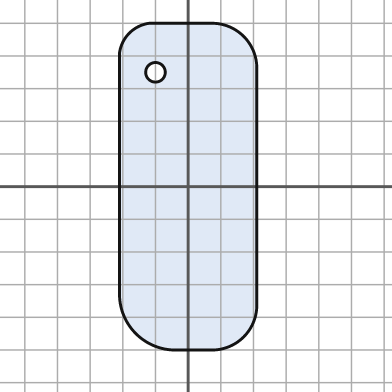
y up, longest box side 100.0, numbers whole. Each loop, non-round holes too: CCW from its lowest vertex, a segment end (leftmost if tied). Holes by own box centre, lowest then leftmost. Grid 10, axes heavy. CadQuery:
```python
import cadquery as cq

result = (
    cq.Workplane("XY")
    .moveTo(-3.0, -50.0)
    .lineTo(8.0, -50.0)
    .threePointArc((17.0, -46.0), (21.0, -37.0))
    .lineTo(21.0, 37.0)
    .threePointArc((17.0, 46.0), (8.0, 50.0))
    .lineTo(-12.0, 50.0)
    .threePointArc((-18.0, 47.0), (-21.0, 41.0))
    .lineTo(-21.0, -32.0)
    .threePointArc((-16.0, -45.0), (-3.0, -50.0))
    .close()
    .moveTo(-10.0, 35.0)
    .circle(3.0)
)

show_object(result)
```